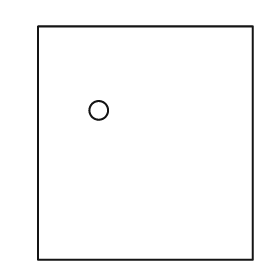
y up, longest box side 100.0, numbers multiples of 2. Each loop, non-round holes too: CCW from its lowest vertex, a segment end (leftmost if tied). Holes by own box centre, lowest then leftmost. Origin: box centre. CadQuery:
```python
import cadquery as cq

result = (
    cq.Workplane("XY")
    .moveTo(-46.0, -50.0)
    .lineTo(46.0, -50.0)
    .lineTo(46.0, 50.0)
    .lineTo(-46.0, 50.0)
    .close()
    .moveTo(-20.0, 14.0)
    .circle(4.0)
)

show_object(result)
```